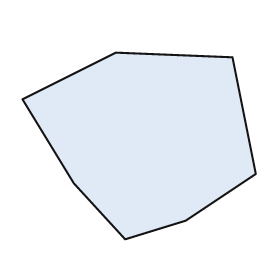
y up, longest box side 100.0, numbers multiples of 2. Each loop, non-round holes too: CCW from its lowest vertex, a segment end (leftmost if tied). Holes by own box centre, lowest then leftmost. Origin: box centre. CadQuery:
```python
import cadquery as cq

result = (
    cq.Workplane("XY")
    .moveTo(-6.0, -40.0)
    .lineTo(20.0, -32.0)
    .lineTo(50.0, -12.0)
    .lineTo(40.0, 38.0)
    .lineTo(-10.0, 40.0)
    .lineTo(-50.0, 20.0)
    .lineTo(-28.0, -16.0)
    .close()
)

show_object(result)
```